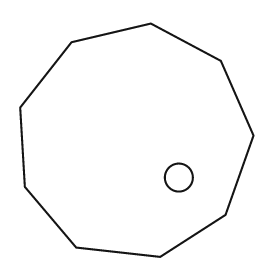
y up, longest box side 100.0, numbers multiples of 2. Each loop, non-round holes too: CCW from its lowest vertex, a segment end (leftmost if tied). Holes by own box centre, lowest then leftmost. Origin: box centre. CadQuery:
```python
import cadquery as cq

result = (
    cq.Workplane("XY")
    .moveTo(10.0, -50.0)
    .lineTo(38.0, -32.0)
    .lineTo(50.0, 2.0)
    .lineTo(36.0, 34.0)
    .lineTo(6.0, 50.0)
    .lineTo(-28.0, 42.0)
    .lineTo(-50.0, 14.0)
    .lineTo(-48.0, -20.0)
    .lineTo(-26.0, -46.0)
    .close()
    .moveTo(18.0, -16.0)
    .circle(6.0)
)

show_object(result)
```